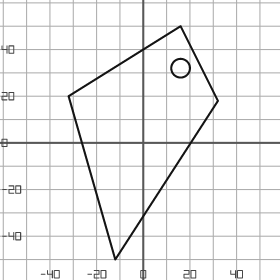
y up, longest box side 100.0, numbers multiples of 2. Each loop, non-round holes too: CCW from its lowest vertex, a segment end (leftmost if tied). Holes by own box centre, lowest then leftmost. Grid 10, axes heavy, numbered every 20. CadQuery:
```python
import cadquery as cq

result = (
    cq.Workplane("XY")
    .moveTo(-12.0, -50.0)
    .lineTo(32.0, 18.0)
    .lineTo(16.0, 50.0)
    .lineTo(-32.0, 20.0)
    .close()
    .moveTo(16.0, 32.0)
    .circle(4.0)
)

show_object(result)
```